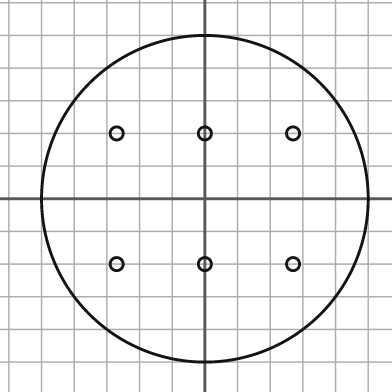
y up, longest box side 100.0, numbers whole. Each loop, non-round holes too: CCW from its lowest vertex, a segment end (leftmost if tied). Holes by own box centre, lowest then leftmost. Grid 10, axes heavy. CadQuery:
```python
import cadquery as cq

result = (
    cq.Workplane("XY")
    .moveTo(0.0, 0.0)
    .circle(50.0)
    .moveTo(-27.0, -20.0)
    .circle(2.0)
    .moveTo(0.0, -20.0)
    .circle(2.0)
    .moveTo(27.0, -20.0)
    .circle(2.0)
    .moveTo(-27.0, 20.0)
    .circle(2.0)
    .moveTo(0.0, 20.0)
    .circle(2.0)
    .moveTo(27.0, 20.0)
    .circle(2.0)
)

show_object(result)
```